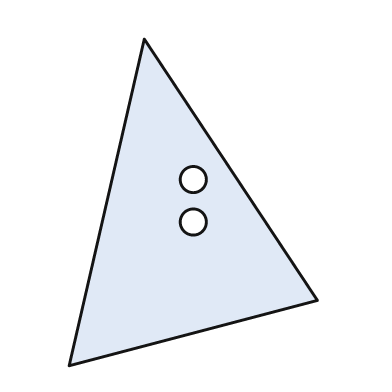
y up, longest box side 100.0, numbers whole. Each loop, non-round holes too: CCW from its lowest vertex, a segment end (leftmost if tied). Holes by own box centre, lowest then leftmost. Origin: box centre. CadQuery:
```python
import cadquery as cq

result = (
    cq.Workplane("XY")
    .moveTo(-38.0, -50.0)
    .lineTo(38.0, -30.0)
    .lineTo(-15.0, 50.0)
    .close()
    .moveTo(0.0, -6.0)
    .circle(4.0)
    .moveTo(0.0, 7.0)
    .circle(4.0)
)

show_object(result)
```